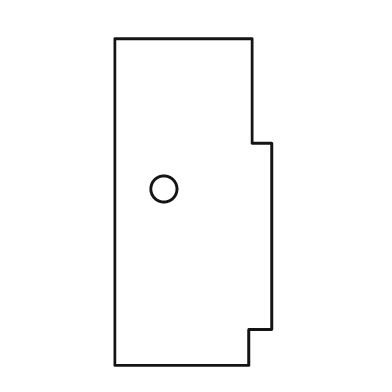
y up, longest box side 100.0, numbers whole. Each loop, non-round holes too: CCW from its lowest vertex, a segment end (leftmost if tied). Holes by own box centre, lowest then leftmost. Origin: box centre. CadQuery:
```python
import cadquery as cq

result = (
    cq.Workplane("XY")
    .moveTo(-24.0, -50.0)
    .lineTo(17.0, -50.0)
    .lineTo(17.0, -39.0)
    .lineTo(24.0, -39.0)
    .lineTo(24.0, 18.0)
    .lineTo(18.0, 18.0)
    .lineTo(18.0, 50.0)
    .lineTo(-24.0, 50.0)
    .close()
    .moveTo(-9.0, 4.0)
    .circle(4.0)
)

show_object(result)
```